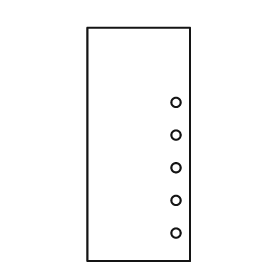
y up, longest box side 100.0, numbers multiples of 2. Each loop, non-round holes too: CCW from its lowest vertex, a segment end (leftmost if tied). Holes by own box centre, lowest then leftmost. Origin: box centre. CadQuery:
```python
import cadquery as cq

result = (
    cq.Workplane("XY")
    .moveTo(-22.0, -50.0)
    .lineTo(22.0, -50.0)
    .lineTo(22.0, 50.0)
    .lineTo(-22.0, 50.0)
    .close()
    .moveTo(16.0, -38.0)
    .circle(2.0)
    .moveTo(16.0, -24.0)
    .circle(2.0)
    .moveTo(16.0, -10.0)
    .circle(2.0)
    .moveTo(16.0, 4.0)
    .circle(2.0)
    .moveTo(16.0, 18.0)
    .circle(2.0)
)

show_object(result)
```